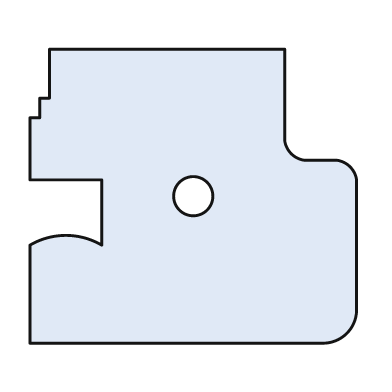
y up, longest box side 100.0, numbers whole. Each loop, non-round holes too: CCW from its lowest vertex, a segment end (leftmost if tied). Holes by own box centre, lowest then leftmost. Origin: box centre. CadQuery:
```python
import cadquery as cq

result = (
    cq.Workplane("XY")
    .moveTo(-50.0, -45.0)
    .lineTo(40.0, -45.0)
    .threePointArc((47.0, -42.0), (50.0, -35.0))
    .lineTo(50.0, 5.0)
    .threePointArc((48.0, 9.0), (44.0, 11.0))
    .lineTo(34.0, 11.0)
    .threePointArc((30.0, 13.0), (28.0, 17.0))
    .lineTo(28.0, 45.0)
    .lineTo(-44.0, 45.0)
    .lineTo(-44.0, 30.0)
    .lineTo(-47.0, 30.0)
    .lineTo(-47.0, 24.0)
    .lineTo(-50.0, 24.0)
    .lineTo(-50.0, 5.0)
    .lineTo(-28.0, 5.0)
    .lineTo(-28.0, -15.0)
    .threePointArc((-39.0, -12.0), (-50.0, -15.0))
    .close()
    .moveTo(0.0, 0.0)
    .circle(6.0)
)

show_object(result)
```